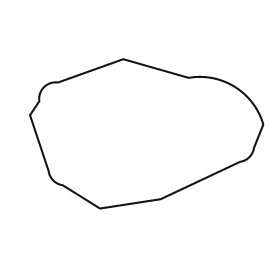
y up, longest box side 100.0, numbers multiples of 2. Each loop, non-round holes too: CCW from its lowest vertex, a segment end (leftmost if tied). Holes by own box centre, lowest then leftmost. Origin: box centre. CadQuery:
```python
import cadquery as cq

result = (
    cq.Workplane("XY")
    .moveTo(-20.0, -32.0)
    .lineTo(6.0, -28.0)
    .lineTo(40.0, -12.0)
    .threePointArc((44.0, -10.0), (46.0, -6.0))
    .lineTo(50.0, 4.0)
    .threePointArc((38.0, 20.0), (18.0, 24.0))
    .lineTo(-10.0, 32.0)
    .lineTo(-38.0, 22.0)
    .threePointArc((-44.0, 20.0), (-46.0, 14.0))
    .lineTo(-50.0, 8.0)
    .lineTo(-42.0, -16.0)
    .threePointArc((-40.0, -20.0), (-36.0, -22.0))
    .close()
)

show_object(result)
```